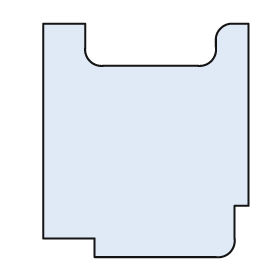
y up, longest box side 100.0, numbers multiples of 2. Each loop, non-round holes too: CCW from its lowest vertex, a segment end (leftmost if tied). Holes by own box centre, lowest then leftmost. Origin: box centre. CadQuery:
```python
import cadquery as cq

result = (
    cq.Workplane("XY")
    .moveTo(-22.0, -50.0)
    .lineTo(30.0, -50.0)
    .threePointArc((36.0, -48.0), (38.0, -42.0))
    .lineTo(38.0, -28.0)
    .lineTo(44.0, -28.0)
    .lineTo(44.0, 50.0)
    .lineTo(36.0, 50.0)
    .threePointArc((32.0, 48.0), (30.0, 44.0))
    .lineTo(30.0, 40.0)
    .threePointArc((28.0, 34.0), (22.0, 32.0))
    .lineTo(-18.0, 32.0)
    .threePointArc((-24.0, 34.0), (-26.0, 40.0))
    .lineTo(-26.0, 50.0)
    .lineTo(-44.0, 50.0)
    .lineTo(-44.0, -42.0)
    .lineTo(-22.0, -42.0)
    .close()
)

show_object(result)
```